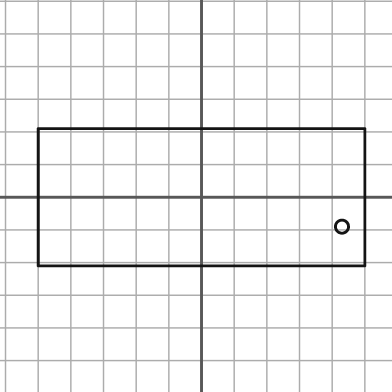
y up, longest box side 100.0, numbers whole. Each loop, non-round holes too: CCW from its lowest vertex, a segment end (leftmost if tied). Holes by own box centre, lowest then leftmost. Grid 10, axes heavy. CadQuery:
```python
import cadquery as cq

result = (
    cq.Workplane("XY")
    .moveTo(-50.0, -21.0)
    .lineTo(50.0, -21.0)
    .lineTo(50.0, 21.0)
    .lineTo(-50.0, 21.0)
    .close()
    .moveTo(43.0, -9.0)
    .circle(2.0)
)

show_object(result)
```